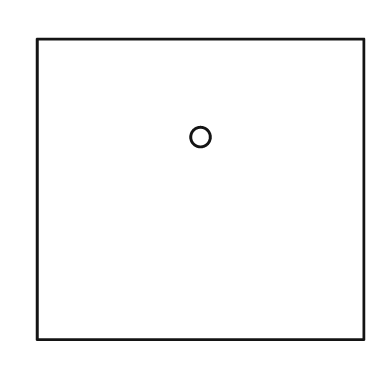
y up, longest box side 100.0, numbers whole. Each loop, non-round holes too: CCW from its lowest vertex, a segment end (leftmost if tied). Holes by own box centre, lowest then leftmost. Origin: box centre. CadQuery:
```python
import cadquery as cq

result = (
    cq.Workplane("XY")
    .moveTo(-50.0, -46.0)
    .lineTo(50.0, -46.0)
    .lineTo(50.0, 46.0)
    .lineTo(-50.0, 46.0)
    .close()
    .moveTo(0.0, 16.0)
    .circle(3.0)
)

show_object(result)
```